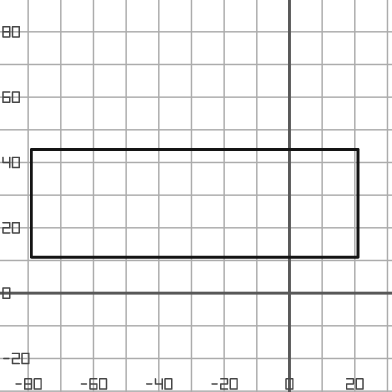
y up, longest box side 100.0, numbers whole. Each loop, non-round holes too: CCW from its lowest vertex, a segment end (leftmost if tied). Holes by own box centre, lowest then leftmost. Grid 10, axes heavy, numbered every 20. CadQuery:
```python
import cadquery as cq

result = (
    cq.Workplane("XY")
    .moveTo(-79.0, 11.0)
    .lineTo(21.0, 11.0)
    .lineTo(21.0, 44.0)
    .lineTo(-79.0, 44.0)
    .close()
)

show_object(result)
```